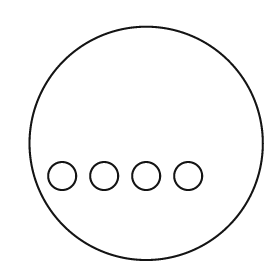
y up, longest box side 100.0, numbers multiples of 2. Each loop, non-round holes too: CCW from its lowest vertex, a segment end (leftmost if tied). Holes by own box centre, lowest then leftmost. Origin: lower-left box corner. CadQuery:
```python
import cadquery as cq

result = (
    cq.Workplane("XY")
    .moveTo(50.0, 50.0)
    .circle(50.0)
    .moveTo(14.0, 36.0)
    .circle(6.0)
    .moveTo(32.0, 36.0)
    .circle(6.0)
    .moveTo(50.0, 36.0)
    .circle(6.0)
    .moveTo(68.0, 36.0)
    .circle(6.0)
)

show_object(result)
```